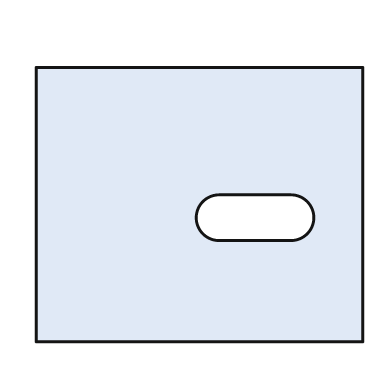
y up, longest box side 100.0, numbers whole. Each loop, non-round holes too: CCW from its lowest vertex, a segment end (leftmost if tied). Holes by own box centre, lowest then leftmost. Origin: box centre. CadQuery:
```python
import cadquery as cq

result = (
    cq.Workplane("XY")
    .moveTo(-50.0, -42.0)
    .lineTo(50.0, -42.0)
    .lineTo(50.0, 42.0)
    .lineTo(-50.0, 42.0)
    .close()
    .moveTo(6.0, -11.0)
    .lineTo(28.0, -11.0)
    .threePointArc((35.0, -4.0), (28.0, 3.0))
    .lineTo(6.0, 3.0)
    .threePointArc((-1.0, -4.0), (6.0, -11.0))
    .close()
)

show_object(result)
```